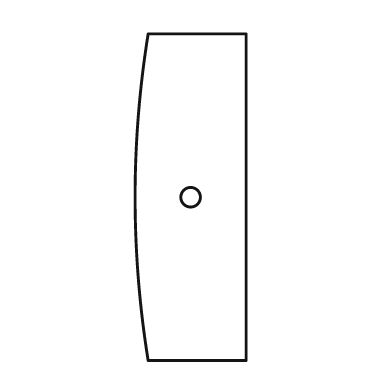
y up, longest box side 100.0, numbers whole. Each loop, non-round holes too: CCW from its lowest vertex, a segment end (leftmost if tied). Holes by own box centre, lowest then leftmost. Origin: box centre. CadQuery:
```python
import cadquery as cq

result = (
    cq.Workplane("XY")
    .moveTo(-13.0, -50.0)
    .lineTo(17.0, -50.0)
    .lineTo(17.0, 50.0)
    .lineTo(-13.0, 50.0)
    .threePointArc((-17.0, 0.0), (-13.0, -50.0))
    .close()
    .moveTo(0.0, 0.0)
    .circle(3.0)
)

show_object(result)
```